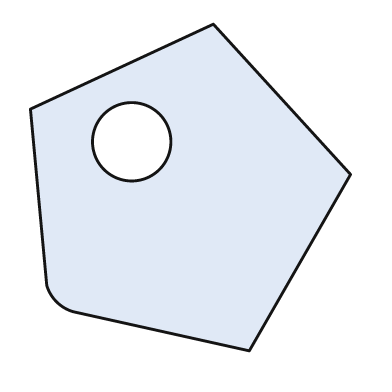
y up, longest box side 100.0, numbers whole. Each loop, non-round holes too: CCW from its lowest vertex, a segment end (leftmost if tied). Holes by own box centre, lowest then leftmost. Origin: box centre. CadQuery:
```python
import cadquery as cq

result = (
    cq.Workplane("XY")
    .moveTo(18.0, -50.0)
    .lineTo(49.0, 4.0)
    .lineTo(7.0, 50.0)
    .lineTo(-49.0, 24.0)
    .lineTo(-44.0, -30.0)
    .threePointArc((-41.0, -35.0), (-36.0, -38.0))
    .close()
    .moveTo(-18.0, 14.0)
    .circle(12.0)
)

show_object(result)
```